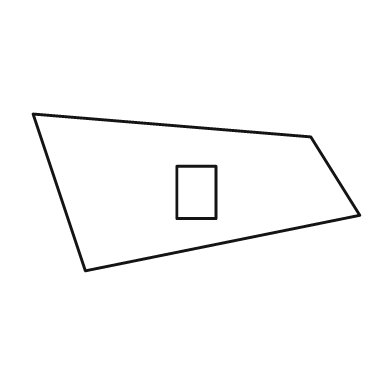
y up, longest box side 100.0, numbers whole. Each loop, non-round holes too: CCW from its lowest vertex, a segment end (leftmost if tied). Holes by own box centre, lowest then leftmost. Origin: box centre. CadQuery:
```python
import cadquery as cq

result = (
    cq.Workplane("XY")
    .moveTo(-34.0, -24.0)
    .lineTo(50.0, -7.0)
    .lineTo(35.0, 17.0)
    .lineTo(-50.0, 24.0)
    .close()
    .moveTo(-6.0, -8.0)
    .lineTo(6.0, -8.0)
    .lineTo(6.0, 8.0)
    .lineTo(-6.0, 8.0)
    .close()
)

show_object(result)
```